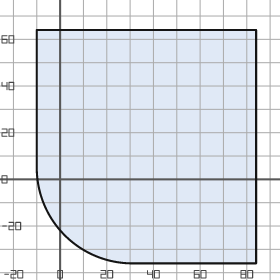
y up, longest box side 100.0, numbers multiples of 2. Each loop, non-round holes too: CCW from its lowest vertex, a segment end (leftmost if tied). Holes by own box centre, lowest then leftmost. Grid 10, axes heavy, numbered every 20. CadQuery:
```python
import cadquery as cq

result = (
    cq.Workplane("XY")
    .moveTo(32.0, -36.0)
    .lineTo(84.0, -36.0)
    .lineTo(84.0, 64.0)
    .lineTo(-10.0, 64.0)
    .lineTo(-10.0, 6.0)
    .threePointArc((2.0, -24.0), (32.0, -36.0))
    .close()
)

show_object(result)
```